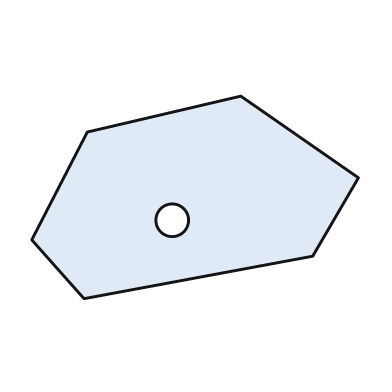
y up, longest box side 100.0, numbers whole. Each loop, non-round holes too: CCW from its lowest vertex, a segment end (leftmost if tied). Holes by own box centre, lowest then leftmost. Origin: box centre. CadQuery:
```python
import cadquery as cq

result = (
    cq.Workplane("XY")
    .moveTo(-34.0, -31.0)
    .lineTo(36.0, -18.0)
    .lineTo(50.0, 6.0)
    .lineTo(14.0, 31.0)
    .lineTo(-33.0, 20.0)
    .lineTo(-50.0, -13.0)
    .close()
    .moveTo(-7.0, -7.0)
    .circle(5.0)
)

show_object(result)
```